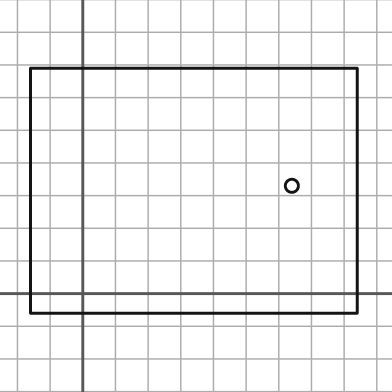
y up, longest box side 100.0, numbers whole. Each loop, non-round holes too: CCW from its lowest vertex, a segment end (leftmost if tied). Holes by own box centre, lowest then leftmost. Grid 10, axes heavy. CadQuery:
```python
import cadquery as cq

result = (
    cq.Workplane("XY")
    .moveTo(-16.0, -6.0)
    .lineTo(84.0, -6.0)
    .lineTo(84.0, 69.0)
    .lineTo(-16.0, 69.0)
    .close()
    .moveTo(64.0, 33.0)
    .circle(2.0)
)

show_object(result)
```